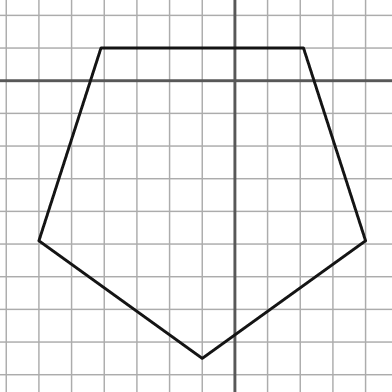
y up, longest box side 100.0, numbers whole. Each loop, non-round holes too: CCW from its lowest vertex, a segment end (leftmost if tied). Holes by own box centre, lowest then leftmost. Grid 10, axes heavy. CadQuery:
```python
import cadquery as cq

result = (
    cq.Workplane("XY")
    .moveTo(-10.0, -85.0)
    .lineTo(40.0, -49.0)
    .lineTo(21.0, 10.0)
    .lineTo(-41.0, 10.0)
    .lineTo(-60.0, -49.0)
    .close()
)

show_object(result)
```